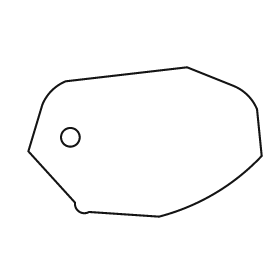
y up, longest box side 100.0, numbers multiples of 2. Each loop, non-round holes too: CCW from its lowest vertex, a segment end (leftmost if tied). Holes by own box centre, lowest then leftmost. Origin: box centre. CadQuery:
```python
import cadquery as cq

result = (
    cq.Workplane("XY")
    .moveTo(6.0, -32.0)
    .threePointArc((30.0, -22.0), (50.0, -6.0))
    .lineTo(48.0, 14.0)
    .threePointArc((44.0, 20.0), (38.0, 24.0))
    .lineTo(18.0, 32.0)
    .lineTo(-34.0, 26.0)
    .threePointArc((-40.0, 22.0), (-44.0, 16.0))
    .lineTo(-50.0, -4.0)
    .lineTo(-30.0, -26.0)
    .threePointArc((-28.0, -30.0), (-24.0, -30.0))
    .close()
    .moveTo(-32.0, 2.0)
    .circle(4.0)
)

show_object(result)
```